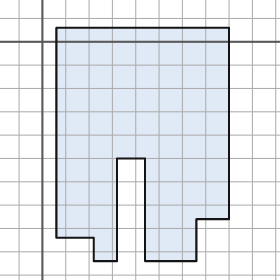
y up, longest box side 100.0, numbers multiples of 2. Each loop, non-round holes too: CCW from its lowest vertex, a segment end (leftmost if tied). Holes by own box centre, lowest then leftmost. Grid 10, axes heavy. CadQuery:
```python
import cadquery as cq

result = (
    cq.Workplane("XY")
    .moveTo(22.0, -94.0)
    .lineTo(32.0, -94.0)
    .lineTo(32.0, -50.0)
    .lineTo(44.0, -50.0)
    .lineTo(44.0, -94.0)
    .lineTo(66.0, -94.0)
    .lineTo(66.0, -76.0)
    .lineTo(80.0, -76.0)
    .lineTo(80.0, 6.0)
    .lineTo(6.0, 6.0)
    .lineTo(6.0, -84.0)
    .lineTo(22.0, -84.0)
    .close()
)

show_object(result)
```